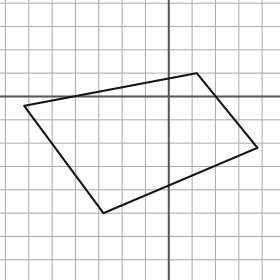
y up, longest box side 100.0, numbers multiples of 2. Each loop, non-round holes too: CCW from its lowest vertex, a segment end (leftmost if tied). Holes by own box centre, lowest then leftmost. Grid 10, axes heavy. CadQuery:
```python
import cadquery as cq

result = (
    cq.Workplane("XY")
    .moveTo(-28.0, -50.0)
    .lineTo(38.0, -22.0)
    .lineTo(12.0, 10.0)
    .lineTo(-62.0, -4.0)
    .close()
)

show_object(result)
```